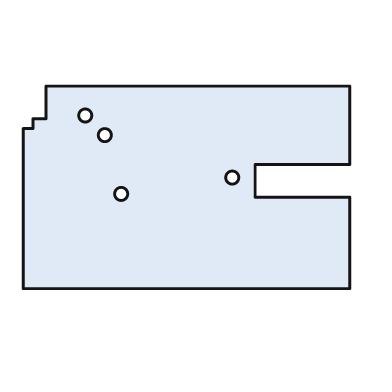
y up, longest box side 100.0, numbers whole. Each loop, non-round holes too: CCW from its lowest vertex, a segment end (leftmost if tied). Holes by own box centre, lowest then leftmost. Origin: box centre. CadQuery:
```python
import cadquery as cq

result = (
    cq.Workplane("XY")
    .moveTo(-50.0, -31.0)
    .lineTo(50.0, -31.0)
    .lineTo(50.0, -3.0)
    .lineTo(21.0, -3.0)
    .lineTo(21.0, 7.0)
    .lineTo(50.0, 7.0)
    .lineTo(50.0, 31.0)
    .lineTo(-43.0, 31.0)
    .lineTo(-43.0, 21.0)
    .lineTo(-47.0, 21.0)
    .lineTo(-47.0, 18.0)
    .lineTo(-50.0, 18.0)
    .close()
    .moveTo(-20.0, -2.0)
    .circle(2.0)
    .moveTo(14.0, 3.0)
    .circle(2.0)
    .moveTo(-25.0, 16.0)
    .circle(2.0)
    .moveTo(-31.0, 22.0)
    .circle(2.0)
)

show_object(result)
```